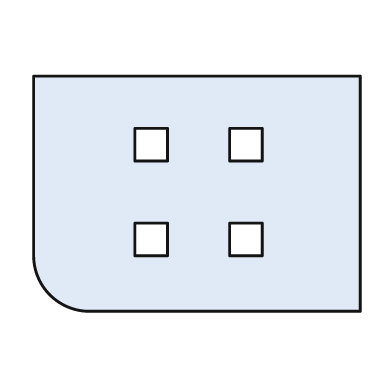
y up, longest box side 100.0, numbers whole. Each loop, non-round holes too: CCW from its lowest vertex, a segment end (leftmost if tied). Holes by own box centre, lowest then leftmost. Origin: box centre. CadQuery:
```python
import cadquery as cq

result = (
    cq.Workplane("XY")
    .moveTo(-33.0, -36.0)
    .lineTo(50.0, -36.0)
    .lineTo(50.0, 36.0)
    .lineTo(-50.0, 36.0)
    .lineTo(-50.0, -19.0)
    .threePointArc((-45.0, -31.0), (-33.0, -36.0))
    .close()
    .moveTo(-19.0, -19.0)
    .lineTo(-9.0, -19.0)
    .lineTo(-9.0, -9.0)
    .lineTo(-19.0, -9.0)
    .close()
    .moveTo(10.0, -19.0)
    .lineTo(20.0, -19.0)
    .lineTo(20.0, -9.0)
    .lineTo(10.0, -9.0)
    .close()
    .moveTo(-19.0, 10.0)
    .lineTo(-9.0, 10.0)
    .lineTo(-9.0, 20.0)
    .lineTo(-19.0, 20.0)
    .close()
    .moveTo(10.0, 10.0)
    .lineTo(20.0, 10.0)
    .lineTo(20.0, 20.0)
    .lineTo(10.0, 20.0)
    .close()
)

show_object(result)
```